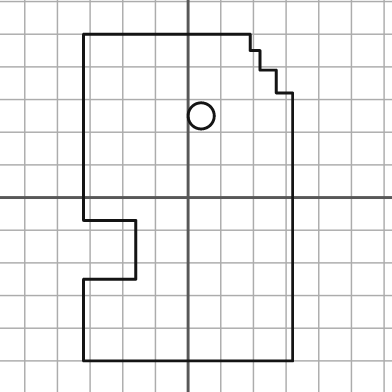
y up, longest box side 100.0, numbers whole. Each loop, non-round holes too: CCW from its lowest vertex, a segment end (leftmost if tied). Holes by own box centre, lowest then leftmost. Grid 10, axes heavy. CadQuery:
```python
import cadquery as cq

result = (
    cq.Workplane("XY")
    .moveTo(-32.0, -50.0)
    .lineTo(32.0, -50.0)
    .lineTo(32.0, 32.0)
    .lineTo(27.0, 32.0)
    .lineTo(27.0, 39.0)
    .lineTo(22.0, 39.0)
    .lineTo(22.0, 45.0)
    .lineTo(19.0, 45.0)
    .lineTo(19.0, 50.0)
    .lineTo(-32.0, 50.0)
    .lineTo(-32.0, -7.0)
    .lineTo(-16.0, -7.0)
    .lineTo(-16.0, -25.0)
    .lineTo(-32.0, -25.0)
    .close()
    .moveTo(4.0, 25.0)
    .circle(4.0)
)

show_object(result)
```